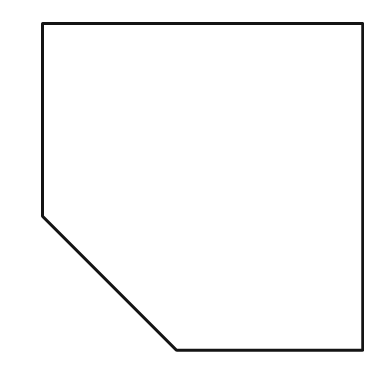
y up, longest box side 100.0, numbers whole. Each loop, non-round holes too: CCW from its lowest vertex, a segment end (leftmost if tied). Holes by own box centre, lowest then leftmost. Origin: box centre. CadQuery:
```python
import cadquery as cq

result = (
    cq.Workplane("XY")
    .moveTo(-8.0, -50.0)
    .lineTo(49.0, -50.0)
    .lineTo(49.0, 50.0)
    .lineTo(-49.0, 50.0)
    .lineTo(-49.0, -9.0)
    .close()
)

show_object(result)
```